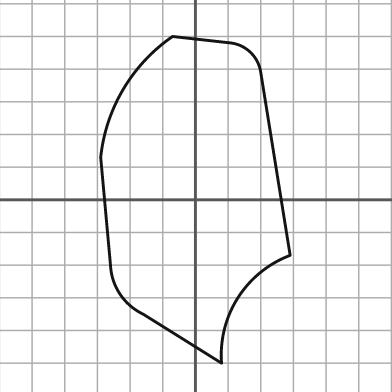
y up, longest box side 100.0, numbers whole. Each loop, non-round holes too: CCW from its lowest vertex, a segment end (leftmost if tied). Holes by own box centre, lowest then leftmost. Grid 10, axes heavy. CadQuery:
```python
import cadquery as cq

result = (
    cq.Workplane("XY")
    .moveTo(8.0, -50.0)
    .threePointArc((13.0, -30.0), (29.0, -17.0))
    .lineTo(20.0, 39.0)
    .threePointArc((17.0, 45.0), (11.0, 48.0))
    .lineTo(-7.0, 50.0)
    .threePointArc((-22.0, 34.0), (-29.0, 13.0))
    .lineTo(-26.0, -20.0)
    .threePointArc((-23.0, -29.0), (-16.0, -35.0))
    .close()
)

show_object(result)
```